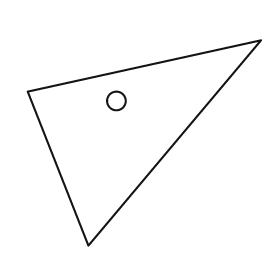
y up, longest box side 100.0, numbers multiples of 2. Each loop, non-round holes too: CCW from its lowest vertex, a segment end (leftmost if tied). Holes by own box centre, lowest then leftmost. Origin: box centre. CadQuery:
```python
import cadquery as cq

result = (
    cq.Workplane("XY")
    .moveTo(-24.0, -44.0)
    .lineTo(50.0, 44.0)
    .lineTo(-50.0, 22.0)
    .close()
    .moveTo(-12.0, 18.0)
    .circle(4.0)
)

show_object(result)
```